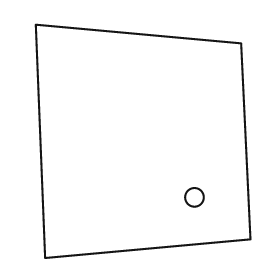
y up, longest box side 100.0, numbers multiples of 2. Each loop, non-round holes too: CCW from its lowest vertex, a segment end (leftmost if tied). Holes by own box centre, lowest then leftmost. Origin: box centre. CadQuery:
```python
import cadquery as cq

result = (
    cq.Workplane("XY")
    .moveTo(-42.0, -50.0)
    .lineTo(46.0, -42.0)
    .lineTo(42.0, 42.0)
    .lineTo(-46.0, 50.0)
    .close()
    .moveTo(22.0, -24.0)
    .circle(4.0)
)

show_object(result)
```